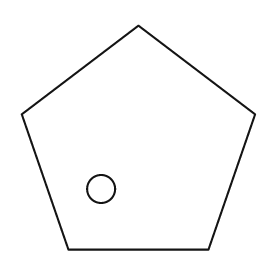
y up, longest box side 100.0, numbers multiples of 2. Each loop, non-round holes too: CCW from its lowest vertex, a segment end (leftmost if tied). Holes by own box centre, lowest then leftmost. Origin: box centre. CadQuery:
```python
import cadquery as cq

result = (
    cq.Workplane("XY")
    .moveTo(-30.0, -48.0)
    .lineTo(30.0, -48.0)
    .lineTo(50.0, 10.0)
    .lineTo(0.0, 48.0)
    .lineTo(-50.0, 10.0)
    .close()
    .moveTo(-16.0, -22.0)
    .circle(6.0)
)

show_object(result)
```